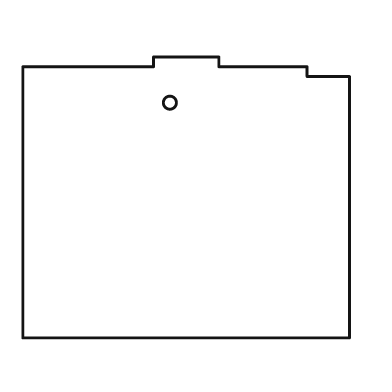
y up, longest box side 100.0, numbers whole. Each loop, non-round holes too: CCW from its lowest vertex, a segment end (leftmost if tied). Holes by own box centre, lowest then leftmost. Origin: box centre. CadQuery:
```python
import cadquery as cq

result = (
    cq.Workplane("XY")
    .moveTo(-50.0, -43.0)
    .lineTo(50.0, -43.0)
    .lineTo(50.0, 37.0)
    .lineTo(37.0, 37.0)
    .lineTo(37.0, 40.0)
    .lineTo(10.0, 40.0)
    .lineTo(10.0, 43.0)
    .lineTo(-10.0, 43.0)
    .lineTo(-10.0, 40.0)
    .lineTo(-50.0, 40.0)
    .close()
    .moveTo(-5.0, 29.0)
    .circle(2.0)
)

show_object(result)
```